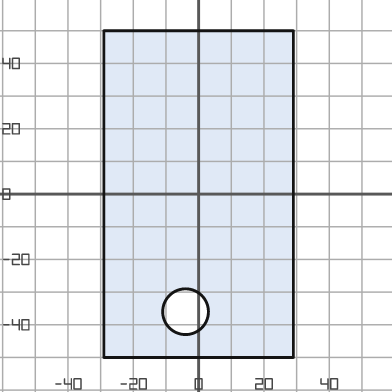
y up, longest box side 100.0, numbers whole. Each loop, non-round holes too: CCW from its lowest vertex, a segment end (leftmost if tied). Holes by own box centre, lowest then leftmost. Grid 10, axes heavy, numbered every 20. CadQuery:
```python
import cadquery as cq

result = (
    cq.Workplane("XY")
    .moveTo(-29.0, -50.0)
    .lineTo(29.0, -50.0)
    .lineTo(29.0, 50.0)
    .lineTo(-29.0, 50.0)
    .close()
    .moveTo(-4.0, -36.0)
    .circle(7.0)
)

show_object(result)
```